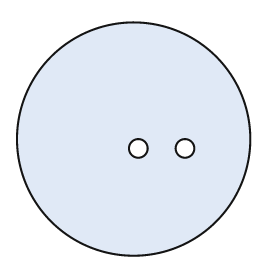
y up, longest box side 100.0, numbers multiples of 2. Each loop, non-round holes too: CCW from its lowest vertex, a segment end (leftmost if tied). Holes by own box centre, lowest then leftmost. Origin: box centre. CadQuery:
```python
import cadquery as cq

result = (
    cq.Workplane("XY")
    .moveTo(0.0, 0.0)
    .circle(50.0)
    .moveTo(2.0, -4.0)
    .circle(4.0)
    .moveTo(22.0, -4.0)
    .circle(4.0)
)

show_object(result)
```